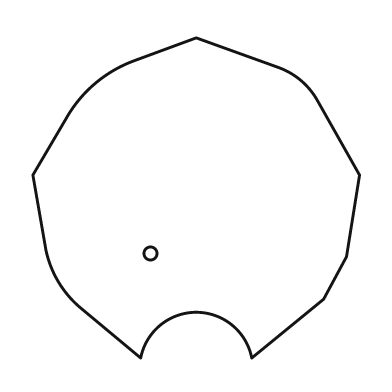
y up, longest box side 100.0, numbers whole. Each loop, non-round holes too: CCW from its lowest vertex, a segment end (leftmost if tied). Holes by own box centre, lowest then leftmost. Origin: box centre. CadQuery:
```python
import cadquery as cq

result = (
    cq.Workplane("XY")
    .moveTo(-17.0, -49.0)
    .threePointArc((0.0, -35.0), (17.0, -49.0))
    .lineTo(39.0, -31.0)
    .lineTo(46.0, -18.0)
    .lineTo(50.0, 7.0)
    .lineTo(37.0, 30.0)
    .threePointArc((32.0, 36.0), (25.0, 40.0))
    .lineTo(0.0, 49.0)
    .lineTo(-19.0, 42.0)
    .threePointArc((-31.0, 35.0), (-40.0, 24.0))
    .lineTo(-50.0, 7.0)
    .lineTo(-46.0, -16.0)
    .threePointArc((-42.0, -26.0), (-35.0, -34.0))
    .close()
    .moveTo(-14.0, -17.0)
    .circle(2.0)
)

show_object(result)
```